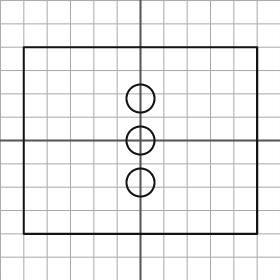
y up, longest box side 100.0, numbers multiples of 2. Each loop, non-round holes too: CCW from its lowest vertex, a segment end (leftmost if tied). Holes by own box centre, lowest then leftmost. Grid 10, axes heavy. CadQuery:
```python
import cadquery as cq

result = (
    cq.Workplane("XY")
    .moveTo(-50.0, -40.0)
    .lineTo(50.0, -40.0)
    .lineTo(50.0, 40.0)
    .lineTo(-50.0, 40.0)
    .close()
    .moveTo(0.0, -18.0)
    .circle(6.0)
    .moveTo(0.0, 0.0)
    .circle(6.0)
    .moveTo(0.0, 18.0)
    .circle(6.0)
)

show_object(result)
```